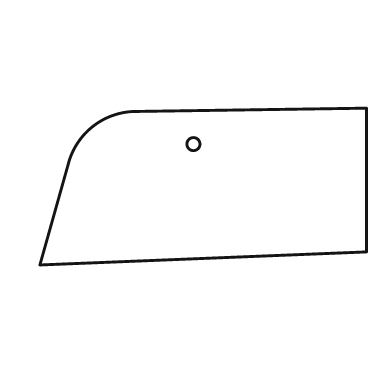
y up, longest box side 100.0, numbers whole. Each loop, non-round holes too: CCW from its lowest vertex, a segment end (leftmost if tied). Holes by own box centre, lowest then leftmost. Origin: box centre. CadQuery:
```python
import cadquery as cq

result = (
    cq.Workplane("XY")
    .moveTo(-50.0, -24.0)
    .lineTo(50.0, -20.0)
    .lineTo(50.0, 24.0)
    .lineTo(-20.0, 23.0)
    .threePointArc((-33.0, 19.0), (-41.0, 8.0))
    .close()
    .moveTo(-3.0, 13.0)
    .circle(2.0)
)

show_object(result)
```